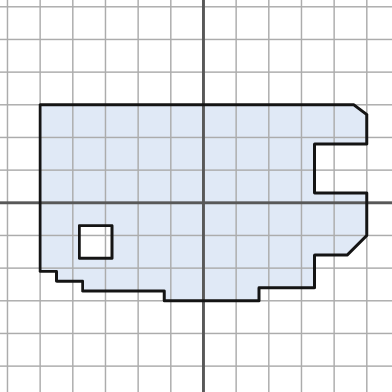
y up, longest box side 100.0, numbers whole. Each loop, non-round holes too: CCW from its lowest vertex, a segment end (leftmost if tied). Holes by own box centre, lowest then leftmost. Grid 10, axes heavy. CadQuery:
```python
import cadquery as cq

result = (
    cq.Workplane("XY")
    .moveTo(-12.0, -30.0)
    .lineTo(17.0, -30.0)
    .lineTo(17.0, -26.0)
    .lineTo(34.0, -26.0)
    .lineTo(34.0, -16.0)
    .lineTo(44.0, -16.0)
    .lineTo(50.0, -10.0)
    .lineTo(50.0, 3.0)
    .lineTo(34.0, 3.0)
    .lineTo(34.0, 18.0)
    .lineTo(50.0, 18.0)
    .lineTo(50.0, 27.0)
    .lineTo(46.0, 30.0)
    .lineTo(-50.0, 30.0)
    .lineTo(-50.0, -21.0)
    .lineTo(-45.0, -21.0)
    .lineTo(-45.0, -24.0)
    .lineTo(-37.0, -24.0)
    .lineTo(-37.0, -27.0)
    .lineTo(-12.0, -27.0)
    .close()
    .moveTo(-38.0, -17.0)
    .lineTo(-28.0, -17.0)
    .lineTo(-28.0, -7.0)
    .lineTo(-38.0, -7.0)
    .close()
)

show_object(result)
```